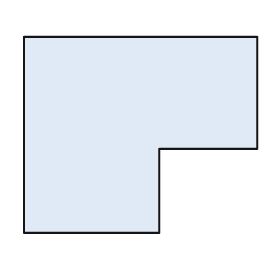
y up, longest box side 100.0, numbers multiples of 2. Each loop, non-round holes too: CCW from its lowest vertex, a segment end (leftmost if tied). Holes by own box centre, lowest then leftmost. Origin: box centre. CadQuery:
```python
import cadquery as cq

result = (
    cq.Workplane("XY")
    .moveTo(-50.0, -42.0)
    .lineTo(8.0, -42.0)
    .lineTo(8.0, -6.0)
    .lineTo(50.0, -6.0)
    .lineTo(50.0, 42.0)
    .lineTo(-50.0, 42.0)
    .close()
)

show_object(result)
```